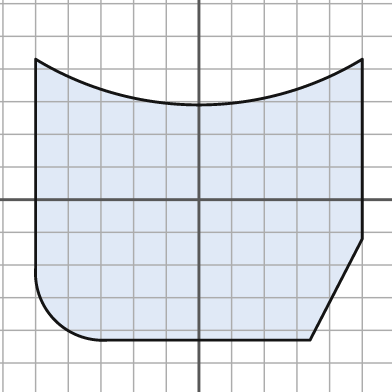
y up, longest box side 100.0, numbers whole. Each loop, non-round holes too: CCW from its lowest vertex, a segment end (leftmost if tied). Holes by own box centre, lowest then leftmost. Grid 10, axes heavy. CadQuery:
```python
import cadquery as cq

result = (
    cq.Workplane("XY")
    .moveTo(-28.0, -43.0)
    .lineTo(34.0, -43.0)
    .lineTo(50.0, -12.0)
    .lineTo(50.0, 43.0)
    .threePointArc((0.0, 29.0), (-50.0, 43.0))
    .lineTo(-50.0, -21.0)
    .threePointArc((-44.0, -37.0), (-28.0, -43.0))
    .close()
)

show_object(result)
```